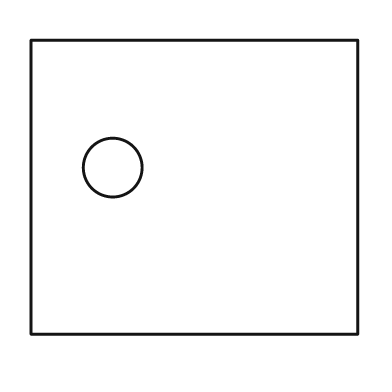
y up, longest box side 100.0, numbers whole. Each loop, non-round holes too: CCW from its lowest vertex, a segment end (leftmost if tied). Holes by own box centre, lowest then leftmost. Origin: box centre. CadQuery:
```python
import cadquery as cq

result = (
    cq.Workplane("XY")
    .moveTo(-50.0, -45.0)
    .lineTo(50.0, -45.0)
    .lineTo(50.0, 45.0)
    .lineTo(-50.0, 45.0)
    .close()
    .moveTo(-25.0, 6.0)
    .circle(9.0)
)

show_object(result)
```